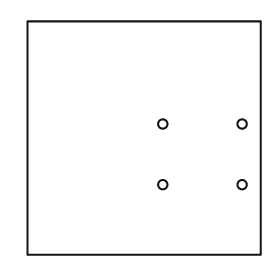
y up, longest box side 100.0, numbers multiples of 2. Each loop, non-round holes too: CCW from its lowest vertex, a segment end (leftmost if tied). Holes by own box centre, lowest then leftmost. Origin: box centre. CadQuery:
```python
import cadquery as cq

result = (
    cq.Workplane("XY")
    .moveTo(-50.0, -50.0)
    .lineTo(50.0, -50.0)
    .lineTo(50.0, 50.0)
    .lineTo(-50.0, 50.0)
    .close()
    .moveTo(8.0, -20.0)
    .circle(2.0)
    .moveTo(42.0, -20.0)
    .circle(2.0)
    .moveTo(8.0, 6.0)
    .circle(2.0)
    .moveTo(42.0, 6.0)
    .circle(2.0)
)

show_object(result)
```